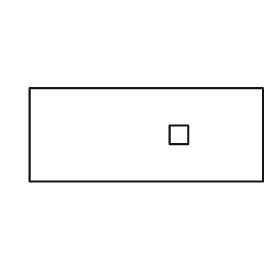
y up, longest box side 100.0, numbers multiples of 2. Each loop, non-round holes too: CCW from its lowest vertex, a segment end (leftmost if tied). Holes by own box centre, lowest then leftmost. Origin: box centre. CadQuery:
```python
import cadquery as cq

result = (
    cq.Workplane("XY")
    .moveTo(-50.0, -20.0)
    .lineTo(50.0, -20.0)
    .lineTo(50.0, 20.0)
    .lineTo(-50.0, 20.0)
    .close()
    .moveTo(10.0, -4.0)
    .lineTo(18.0, -4.0)
    .lineTo(18.0, 4.0)
    .lineTo(10.0, 4.0)
    .close()
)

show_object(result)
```